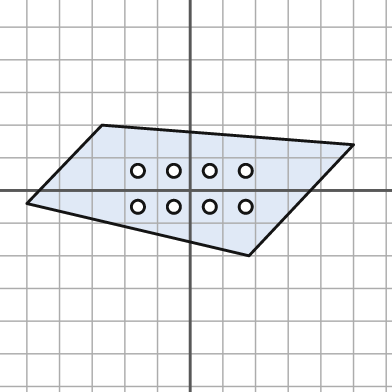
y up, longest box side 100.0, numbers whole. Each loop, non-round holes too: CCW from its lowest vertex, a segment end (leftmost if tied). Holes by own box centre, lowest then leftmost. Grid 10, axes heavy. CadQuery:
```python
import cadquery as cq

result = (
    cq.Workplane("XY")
    .moveTo(18.0, -20.0)
    .lineTo(50.0, 14.0)
    .lineTo(-27.0, 20.0)
    .lineTo(-50.0, -4.0)
    .close()
    .moveTo(-16.0, -5.0)
    .circle(2.0)
    .moveTo(-5.0, -5.0)
    .circle(2.0)
    .moveTo(6.0, -5.0)
    .circle(2.0)
    .moveTo(17.0, -5.0)
    .circle(2.0)
    .moveTo(-16.0, 6.0)
    .circle(2.0)
    .moveTo(-5.0, 6.0)
    .circle(2.0)
    .moveTo(6.0, 6.0)
    .circle(2.0)
    .moveTo(17.0, 6.0)
    .circle(2.0)
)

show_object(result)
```